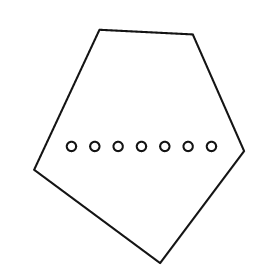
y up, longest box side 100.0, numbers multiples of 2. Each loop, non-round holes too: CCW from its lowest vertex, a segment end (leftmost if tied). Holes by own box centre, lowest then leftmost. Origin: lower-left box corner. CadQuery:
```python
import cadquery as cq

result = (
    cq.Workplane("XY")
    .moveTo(54.0, 0.0)
    .lineTo(90.0, 48.0)
    .lineTo(68.0, 98.0)
    .lineTo(28.0, 100.0)
    .lineTo(0.0, 40.0)
    .close()
    .moveTo(16.0, 50.0)
    .circle(2.0)
    .moveTo(26.0, 50.0)
    .circle(2.0)
    .moveTo(36.0, 50.0)
    .circle(2.0)
    .moveTo(46.0, 50.0)
    .circle(2.0)
    .moveTo(56.0, 50.0)
    .circle(2.0)
    .moveTo(66.0, 50.0)
    .circle(2.0)
    .moveTo(76.0, 50.0)
    .circle(2.0)
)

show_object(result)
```